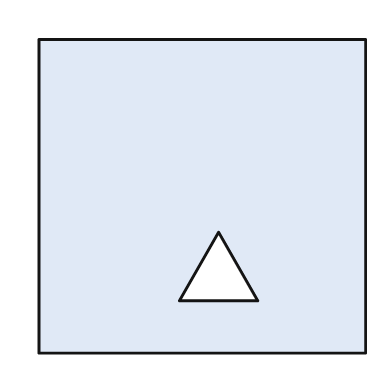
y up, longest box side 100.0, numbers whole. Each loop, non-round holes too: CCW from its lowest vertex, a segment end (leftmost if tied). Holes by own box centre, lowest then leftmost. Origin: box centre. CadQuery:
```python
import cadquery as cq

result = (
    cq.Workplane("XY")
    .moveTo(-50.0, -48.0)
    .lineTo(50.0, -48.0)
    .lineTo(50.0, 48.0)
    .lineTo(-50.0, 48.0)
    .close()
    .moveTo(-7.0, -32.0)
    .lineTo(17.0, -32.0)
    .lineTo(5.0, -11.0)
    .close()
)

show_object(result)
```